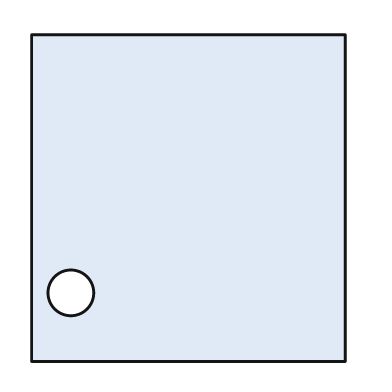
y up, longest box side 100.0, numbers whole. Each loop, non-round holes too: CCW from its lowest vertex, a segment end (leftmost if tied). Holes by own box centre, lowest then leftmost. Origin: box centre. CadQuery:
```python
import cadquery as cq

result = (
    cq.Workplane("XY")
    .moveTo(-48.0, -50.0)
    .lineTo(48.0, -50.0)
    .lineTo(48.0, 50.0)
    .lineTo(-48.0, 50.0)
    .close()
    .moveTo(-36.0, -29.0)
    .circle(7.0)
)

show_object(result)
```